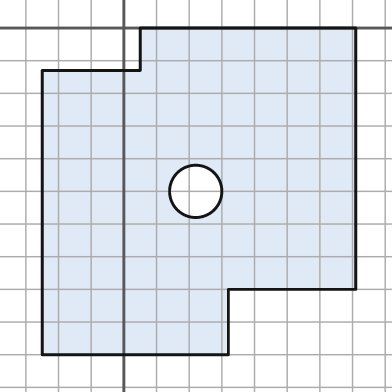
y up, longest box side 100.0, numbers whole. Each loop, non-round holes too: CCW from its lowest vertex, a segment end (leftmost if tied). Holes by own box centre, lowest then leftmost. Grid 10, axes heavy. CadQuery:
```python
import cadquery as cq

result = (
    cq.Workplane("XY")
    .moveTo(-25.0, -100.0)
    .lineTo(32.0, -100.0)
    .lineTo(32.0, -80.0)
    .lineTo(71.0, -80.0)
    .lineTo(71.0, 0.0)
    .lineTo(5.0, 0.0)
    .lineTo(5.0, -13.0)
    .lineTo(-25.0, -13.0)
    .close()
    .moveTo(22.0, -50.0)
    .circle(8.0)
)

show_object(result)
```